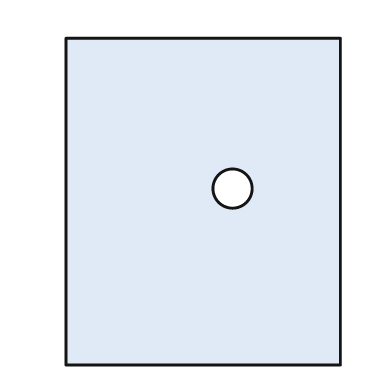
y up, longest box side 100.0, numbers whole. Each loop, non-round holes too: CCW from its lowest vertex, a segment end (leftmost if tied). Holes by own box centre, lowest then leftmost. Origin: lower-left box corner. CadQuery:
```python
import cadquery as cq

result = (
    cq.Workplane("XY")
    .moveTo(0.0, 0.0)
    .lineTo(84.0, 0.0)
    .lineTo(84.0, 100.0)
    .lineTo(0.0, 100.0)
    .close()
    .moveTo(51.0, 54.0)
    .circle(6.0)
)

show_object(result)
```